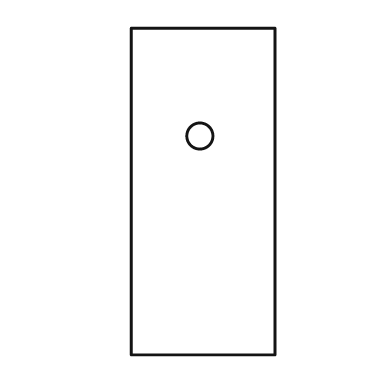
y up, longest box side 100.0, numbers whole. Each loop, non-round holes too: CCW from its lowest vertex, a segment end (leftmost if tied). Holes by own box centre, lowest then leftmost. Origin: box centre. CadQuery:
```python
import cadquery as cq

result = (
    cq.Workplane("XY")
    .moveTo(-22.0, -50.0)
    .lineTo(22.0, -50.0)
    .lineTo(22.0, 50.0)
    .lineTo(-22.0, 50.0)
    .close()
    .moveTo(-1.0, 17.0)
    .circle(4.0)
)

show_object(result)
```